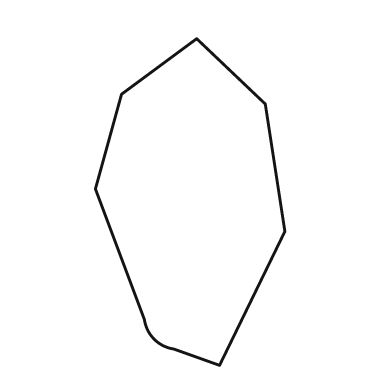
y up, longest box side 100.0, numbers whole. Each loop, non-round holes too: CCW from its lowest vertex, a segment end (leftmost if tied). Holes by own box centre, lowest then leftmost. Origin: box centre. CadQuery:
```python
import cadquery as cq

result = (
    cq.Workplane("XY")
    .moveTo(9.0, -50.0)
    .lineTo(29.0, -9.0)
    .lineTo(23.0, 30.0)
    .lineTo(2.0, 50.0)
    .lineTo(-21.0, 33.0)
    .lineTo(-29.0, 4.0)
    .lineTo(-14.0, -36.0)
    .threePointArc((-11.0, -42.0), (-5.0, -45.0))
    .close()
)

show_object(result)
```